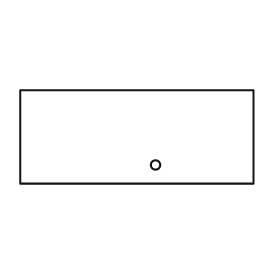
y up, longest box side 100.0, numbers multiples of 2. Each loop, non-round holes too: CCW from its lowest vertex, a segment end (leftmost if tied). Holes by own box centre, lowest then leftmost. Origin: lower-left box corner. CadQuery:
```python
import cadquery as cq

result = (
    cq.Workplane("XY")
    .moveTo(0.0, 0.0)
    .lineTo(100.0, 0.0)
    .lineTo(100.0, 40.0)
    .lineTo(0.0, 40.0)
    .close()
    .moveTo(58.0, 8.0)
    .circle(2.0)
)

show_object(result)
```